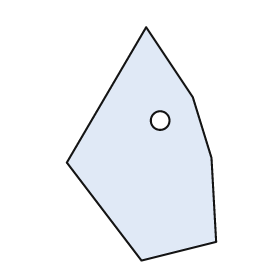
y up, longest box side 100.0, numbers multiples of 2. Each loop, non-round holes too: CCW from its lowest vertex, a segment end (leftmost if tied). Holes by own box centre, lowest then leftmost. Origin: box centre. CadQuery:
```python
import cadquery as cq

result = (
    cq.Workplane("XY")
    .moveTo(0.0, -50.0)
    .lineTo(32.0, -42.0)
    .lineTo(30.0, -6.0)
    .lineTo(22.0, 20.0)
    .lineTo(2.0, 50.0)
    .lineTo(-32.0, -8.0)
    .close()
    .moveTo(8.0, 10.0)
    .circle(4.0)
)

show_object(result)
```